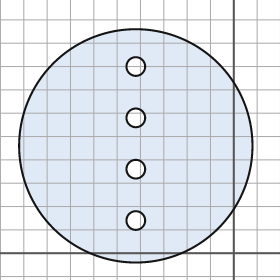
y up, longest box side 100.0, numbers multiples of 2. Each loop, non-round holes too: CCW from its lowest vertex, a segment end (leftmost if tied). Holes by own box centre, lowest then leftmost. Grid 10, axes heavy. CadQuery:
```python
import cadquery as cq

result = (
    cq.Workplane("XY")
    .moveTo(-42.0, 46.0)
    .circle(50.0)
    .moveTo(-42.0, 14.0)
    .circle(4.0)
    .moveTo(-42.0, 36.0)
    .circle(4.0)
    .moveTo(-42.0, 58.0)
    .circle(4.0)
    .moveTo(-42.0, 80.0)
    .circle(4.0)
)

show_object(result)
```